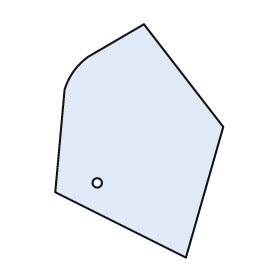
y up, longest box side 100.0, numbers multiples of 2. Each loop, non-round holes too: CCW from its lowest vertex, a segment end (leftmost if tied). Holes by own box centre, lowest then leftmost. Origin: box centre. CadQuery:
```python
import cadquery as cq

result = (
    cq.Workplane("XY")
    .moveTo(20.0, -50.0)
    .lineTo(36.0, 6.0)
    .lineTo(2.0, 50.0)
    .lineTo(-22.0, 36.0)
    .threePointArc((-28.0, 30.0), (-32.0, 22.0))
    .lineTo(-36.0, -22.0)
    .close()
    .moveTo(-18.0, -18.0)
    .circle(2.0)
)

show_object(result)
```